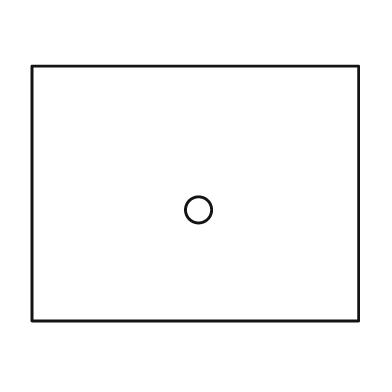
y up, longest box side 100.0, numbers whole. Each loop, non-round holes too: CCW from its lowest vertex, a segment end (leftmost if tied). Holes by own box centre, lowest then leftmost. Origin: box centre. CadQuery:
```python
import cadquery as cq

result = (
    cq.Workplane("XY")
    .moveTo(-50.0, -39.0)
    .lineTo(50.0, -39.0)
    .lineTo(50.0, 39.0)
    .lineTo(-50.0, 39.0)
    .close()
    .moveTo(1.0, -5.0)
    .circle(4.0)
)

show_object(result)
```